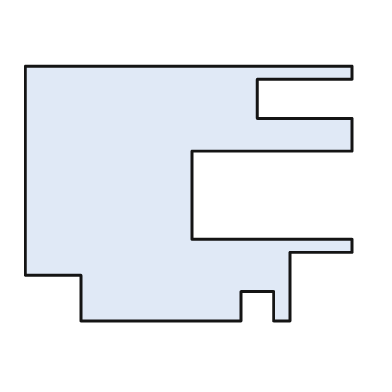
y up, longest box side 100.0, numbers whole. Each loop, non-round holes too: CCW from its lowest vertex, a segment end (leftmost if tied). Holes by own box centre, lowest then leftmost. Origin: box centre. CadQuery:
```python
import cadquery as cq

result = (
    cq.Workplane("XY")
    .moveTo(-33.0, -39.0)
    .lineTo(16.0, -39.0)
    .lineTo(16.0, -30.0)
    .lineTo(26.0, -30.0)
    .lineTo(26.0, -39.0)
    .lineTo(31.0, -39.0)
    .lineTo(31.0, -18.0)
    .lineTo(50.0, -18.0)
    .lineTo(50.0, -14.0)
    .lineTo(1.0, -14.0)
    .lineTo(1.0, 13.0)
    .lineTo(50.0, 13.0)
    .lineTo(50.0, 23.0)
    .lineTo(21.0, 23.0)
    .lineTo(21.0, 35.0)
    .lineTo(50.0, 35.0)
    .lineTo(50.0, 39.0)
    .lineTo(-50.0, 39.0)
    .lineTo(-50.0, -25.0)
    .lineTo(-33.0, -25.0)
    .close()
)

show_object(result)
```